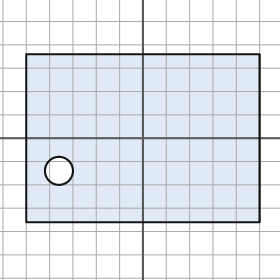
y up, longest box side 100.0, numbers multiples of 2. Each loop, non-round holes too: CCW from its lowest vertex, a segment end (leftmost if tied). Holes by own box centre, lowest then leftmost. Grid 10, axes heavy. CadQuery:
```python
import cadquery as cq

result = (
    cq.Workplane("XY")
    .moveTo(-50.0, -36.0)
    .lineTo(50.0, -36.0)
    .lineTo(50.0, 36.0)
    .lineTo(-50.0, 36.0)
    .close()
    .moveTo(-36.0, -14.0)
    .circle(6.0)
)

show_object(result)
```